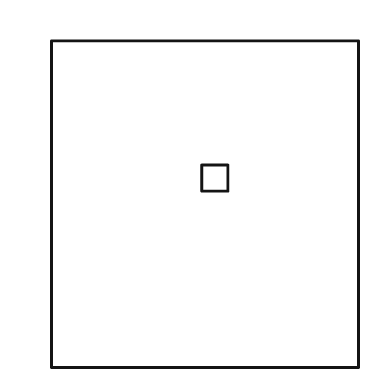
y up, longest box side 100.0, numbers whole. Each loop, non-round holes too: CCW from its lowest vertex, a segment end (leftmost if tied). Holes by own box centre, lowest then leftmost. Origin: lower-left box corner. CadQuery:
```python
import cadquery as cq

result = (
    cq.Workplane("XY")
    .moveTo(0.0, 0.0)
    .lineTo(94.0, 0.0)
    .lineTo(94.0, 100.0)
    .lineTo(0.0, 100.0)
    .close()
    .moveTo(46.0, 54.0)
    .lineTo(54.0, 54.0)
    .lineTo(54.0, 62.0)
    .lineTo(46.0, 62.0)
    .close()
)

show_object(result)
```